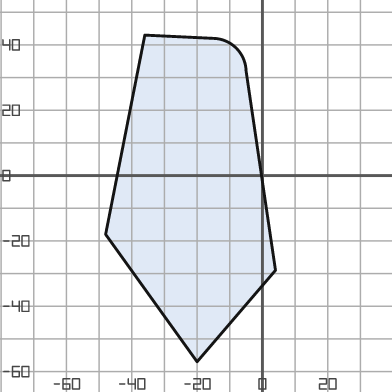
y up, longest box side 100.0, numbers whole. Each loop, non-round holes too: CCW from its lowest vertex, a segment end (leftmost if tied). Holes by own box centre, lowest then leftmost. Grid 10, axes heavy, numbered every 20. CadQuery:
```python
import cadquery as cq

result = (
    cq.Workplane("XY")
    .moveTo(-20.0, -57.0)
    .lineTo(4.0, -29.0)
    .lineTo(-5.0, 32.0)
    .threePointArc((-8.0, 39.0), (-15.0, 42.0))
    .lineTo(-36.0, 43.0)
    .lineTo(-48.0, -18.0)
    .close()
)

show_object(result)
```